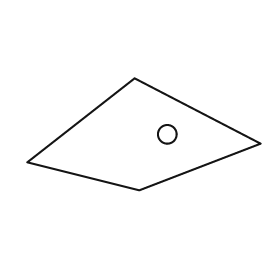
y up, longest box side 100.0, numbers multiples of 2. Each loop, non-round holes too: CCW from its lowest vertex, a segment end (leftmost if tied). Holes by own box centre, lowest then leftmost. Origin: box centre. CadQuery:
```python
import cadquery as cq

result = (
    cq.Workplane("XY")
    .moveTo(-2.0, -24.0)
    .lineTo(50.0, -4.0)
    .lineTo(-4.0, 24.0)
    .lineTo(-50.0, -12.0)
    .close()
    .moveTo(10.0, 0.0)
    .circle(4.0)
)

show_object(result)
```